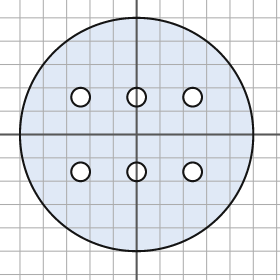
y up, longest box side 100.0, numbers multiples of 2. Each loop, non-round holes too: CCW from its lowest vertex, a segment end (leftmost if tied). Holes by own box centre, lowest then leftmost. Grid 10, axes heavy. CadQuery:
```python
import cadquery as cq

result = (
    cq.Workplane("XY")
    .moveTo(0.0, 0.0)
    .circle(50.0)
    .moveTo(-24.0, -16.0)
    .circle(4.0)
    .moveTo(0.0, -16.0)
    .circle(4.0)
    .moveTo(24.0, -16.0)
    .circle(4.0)
    .moveTo(-24.0, 16.0)
    .circle(4.0)
    .moveTo(0.0, 16.0)
    .circle(4.0)
    .moveTo(24.0, 16.0)
    .circle(4.0)
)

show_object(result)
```